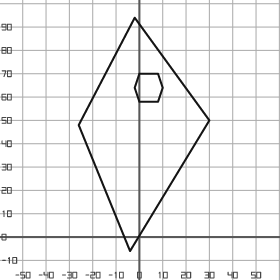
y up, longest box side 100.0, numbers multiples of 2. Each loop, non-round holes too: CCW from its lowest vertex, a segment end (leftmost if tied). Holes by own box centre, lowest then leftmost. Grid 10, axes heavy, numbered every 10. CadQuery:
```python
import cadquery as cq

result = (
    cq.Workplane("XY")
    .moveTo(-4.0, -6.0)
    .lineTo(30.0, 50.0)
    .lineTo(-2.0, 94.0)
    .lineTo(-26.0, 48.0)
    .close()
    .moveTo(0.0, 58.0)
    .lineTo(8.0, 58.0)
    .lineTo(10.0, 64.0)
    .lineTo(8.0, 70.0)
    .lineTo(0.0, 70.0)
    .lineTo(-2.0, 64.0)
    .close()
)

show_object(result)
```